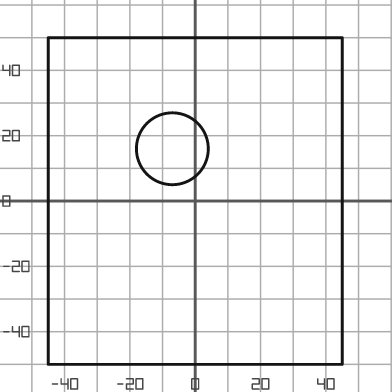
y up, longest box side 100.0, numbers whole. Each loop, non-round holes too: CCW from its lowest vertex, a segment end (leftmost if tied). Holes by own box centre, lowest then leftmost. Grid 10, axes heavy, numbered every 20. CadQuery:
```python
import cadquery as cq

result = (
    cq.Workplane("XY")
    .moveTo(-45.0, -50.0)
    .lineTo(45.0, -50.0)
    .lineTo(45.0, 50.0)
    .lineTo(-45.0, 50.0)
    .close()
    .moveTo(-7.0, 16.0)
    .circle(11.0)
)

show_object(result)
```